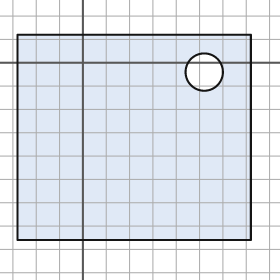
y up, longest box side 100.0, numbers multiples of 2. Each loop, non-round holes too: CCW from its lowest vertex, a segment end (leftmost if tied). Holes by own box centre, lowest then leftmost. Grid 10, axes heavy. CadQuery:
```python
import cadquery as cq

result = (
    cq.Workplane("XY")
    .moveTo(-28.0, -76.0)
    .lineTo(72.0, -76.0)
    .lineTo(72.0, 12.0)
    .lineTo(-28.0, 12.0)
    .close()
    .moveTo(52.0, -4.0)
    .circle(8.0)
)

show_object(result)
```